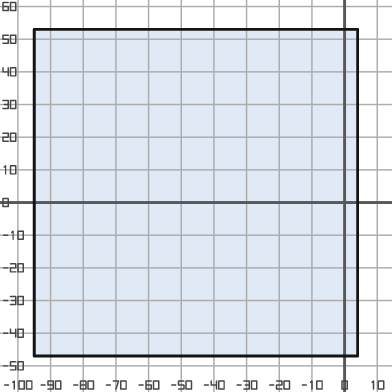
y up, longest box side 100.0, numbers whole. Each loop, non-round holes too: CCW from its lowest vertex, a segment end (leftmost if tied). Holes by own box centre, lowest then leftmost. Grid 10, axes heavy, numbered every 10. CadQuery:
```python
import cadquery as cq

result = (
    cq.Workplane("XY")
    .moveTo(-95.0, -47.0)
    .lineTo(4.0, -47.0)
    .lineTo(4.0, 53.0)
    .lineTo(-95.0, 53.0)
    .close()
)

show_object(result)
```